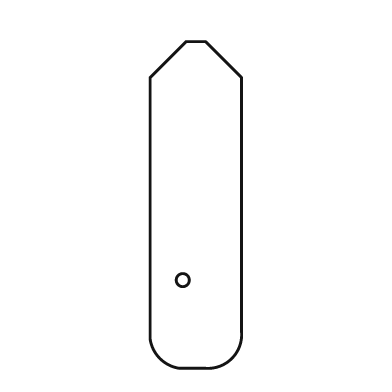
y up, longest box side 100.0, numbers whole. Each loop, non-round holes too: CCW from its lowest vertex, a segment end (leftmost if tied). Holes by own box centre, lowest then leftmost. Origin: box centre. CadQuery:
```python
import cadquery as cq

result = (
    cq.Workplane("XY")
    .moveTo(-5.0, -50.0)
    .lineTo(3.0, -50.0)
    .threePointArc((11.0, -47.0), (14.0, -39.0))
    .lineTo(14.0, 39.0)
    .lineTo(3.0, 50.0)
    .lineTo(-3.0, 50.0)
    .lineTo(-14.0, 39.0)
    .lineTo(-14.0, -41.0)
    .threePointArc((-11.0, -47.0), (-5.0, -50.0))
    .close()
    .moveTo(-4.0, -23.0)
    .circle(2.0)
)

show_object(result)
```